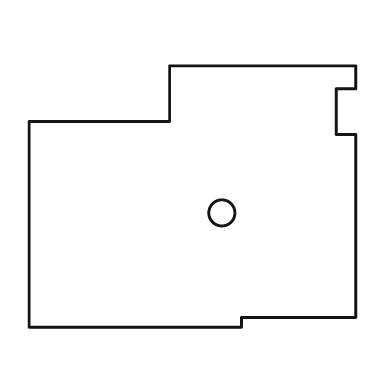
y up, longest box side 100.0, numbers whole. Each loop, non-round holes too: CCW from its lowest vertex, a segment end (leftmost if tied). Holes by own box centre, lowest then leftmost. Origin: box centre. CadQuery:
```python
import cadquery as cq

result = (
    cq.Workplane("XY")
    .moveTo(-50.0, -40.0)
    .lineTo(15.0, -40.0)
    .lineTo(15.0, -37.0)
    .lineTo(50.0, -37.0)
    .lineTo(50.0, 19.0)
    .lineTo(44.0, 19.0)
    .lineTo(44.0, 33.0)
    .lineTo(50.0, 33.0)
    .lineTo(50.0, 40.0)
    .lineTo(-7.0, 40.0)
    .lineTo(-7.0, 23.0)
    .lineTo(-50.0, 23.0)
    .close()
    .moveTo(9.0, -5.0)
    .circle(4.0)
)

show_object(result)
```